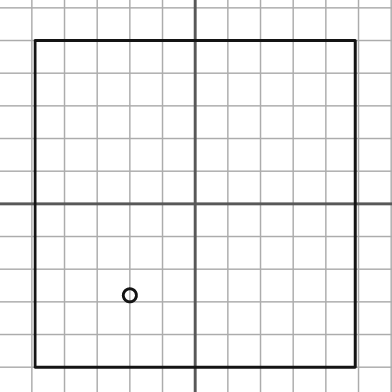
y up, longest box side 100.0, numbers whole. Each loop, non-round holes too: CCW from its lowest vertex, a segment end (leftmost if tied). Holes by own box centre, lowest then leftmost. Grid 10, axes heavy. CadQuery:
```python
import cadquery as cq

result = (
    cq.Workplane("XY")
    .moveTo(-49.0, -50.0)
    .lineTo(49.0, -50.0)
    .lineTo(49.0, 50.0)
    .lineTo(-49.0, 50.0)
    .close()
    .moveTo(-20.0, -28.0)
    .circle(2.0)
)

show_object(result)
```